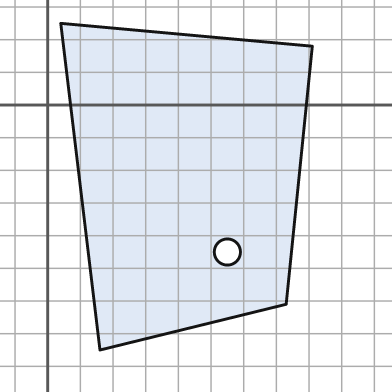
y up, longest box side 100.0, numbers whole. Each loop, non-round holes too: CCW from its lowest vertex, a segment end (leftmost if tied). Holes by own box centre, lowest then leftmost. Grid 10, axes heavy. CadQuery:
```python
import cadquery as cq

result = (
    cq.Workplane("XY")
    .moveTo(16.0, -75.0)
    .lineTo(73.0, -61.0)
    .lineTo(81.0, 18.0)
    .lineTo(4.0, 25.0)
    .close()
    .moveTo(55.0, -45.0)
    .circle(4.0)
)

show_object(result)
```